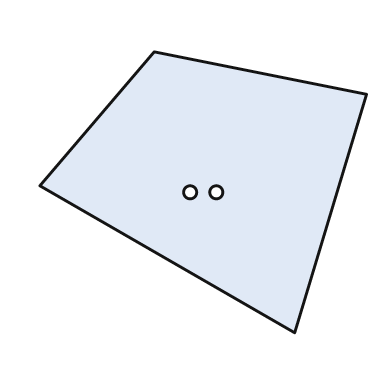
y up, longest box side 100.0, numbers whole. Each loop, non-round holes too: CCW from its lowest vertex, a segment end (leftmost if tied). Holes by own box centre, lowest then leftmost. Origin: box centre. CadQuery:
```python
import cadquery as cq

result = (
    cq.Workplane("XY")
    .moveTo(28.0, -43.0)
    .lineTo(50.0, 30.0)
    .lineTo(-15.0, 43.0)
    .lineTo(-50.0, 2.0)
    .close()
    .moveTo(-4.0, 0.0)
    .circle(2.0)
    .moveTo(4.0, 0.0)
    .circle(2.0)
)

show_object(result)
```